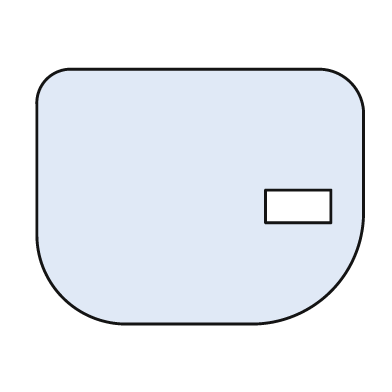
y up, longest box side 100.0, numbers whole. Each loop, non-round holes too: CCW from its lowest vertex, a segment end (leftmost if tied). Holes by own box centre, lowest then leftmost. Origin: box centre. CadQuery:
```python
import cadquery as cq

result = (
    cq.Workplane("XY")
    .moveTo(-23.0, -39.0)
    .lineTo(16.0, -39.0)
    .threePointArc((40.0, -29.0), (50.0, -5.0))
    .lineTo(50.0, 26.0)
    .threePointArc((46.0, 35.0), (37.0, 39.0))
    .lineTo(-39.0, 39.0)
    .threePointArc((-47.0, 36.0), (-50.0, 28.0))
    .lineTo(-50.0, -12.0)
    .threePointArc((-42.0, -31.0), (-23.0, -39.0))
    .close()
    .moveTo(20.0, -8.0)
    .lineTo(40.0, -8.0)
    .lineTo(40.0, 2.0)
    .lineTo(20.0, 2.0)
    .close()
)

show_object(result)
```